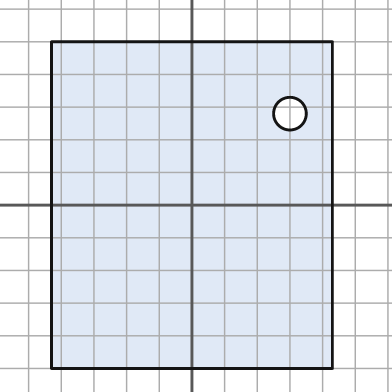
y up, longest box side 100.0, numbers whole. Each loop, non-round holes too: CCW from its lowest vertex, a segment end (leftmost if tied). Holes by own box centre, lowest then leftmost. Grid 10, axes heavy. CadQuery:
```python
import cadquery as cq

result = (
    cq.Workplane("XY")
    .moveTo(-43.0, -50.0)
    .lineTo(43.0, -50.0)
    .lineTo(43.0, 50.0)
    .lineTo(-43.0, 50.0)
    .close()
    .moveTo(30.0, 28.0)
    .circle(5.0)
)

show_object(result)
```